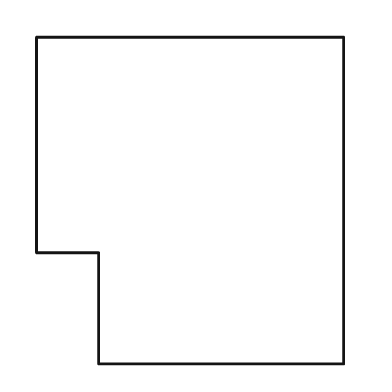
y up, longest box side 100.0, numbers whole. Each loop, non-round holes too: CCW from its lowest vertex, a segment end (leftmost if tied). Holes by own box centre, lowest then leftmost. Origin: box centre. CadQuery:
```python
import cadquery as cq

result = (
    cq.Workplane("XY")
    .moveTo(-28.0, -50.0)
    .lineTo(47.0, -50.0)
    .lineTo(47.0, 50.0)
    .lineTo(-47.0, 50.0)
    .lineTo(-47.0, -16.0)
    .lineTo(-28.0, -16.0)
    .close()
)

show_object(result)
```